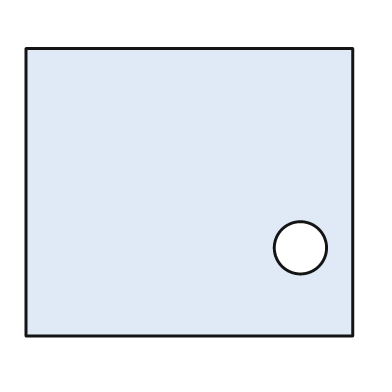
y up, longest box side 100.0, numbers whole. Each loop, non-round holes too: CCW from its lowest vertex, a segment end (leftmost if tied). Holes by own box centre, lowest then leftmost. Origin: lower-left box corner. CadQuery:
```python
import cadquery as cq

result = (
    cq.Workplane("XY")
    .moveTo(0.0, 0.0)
    .lineTo(100.0, 0.0)
    .lineTo(100.0, 88.0)
    .lineTo(0.0, 88.0)
    .close()
    .moveTo(84.0, 27.0)
    .circle(8.0)
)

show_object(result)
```